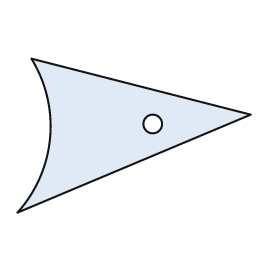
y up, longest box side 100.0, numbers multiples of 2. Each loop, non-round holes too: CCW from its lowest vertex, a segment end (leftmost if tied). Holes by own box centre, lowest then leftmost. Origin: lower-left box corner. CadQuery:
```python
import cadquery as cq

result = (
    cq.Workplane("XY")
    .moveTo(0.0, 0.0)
    .lineTo(100.0, 42.0)
    .lineTo(6.0, 66.0)
    .threePointArc((14.0, 32.0), (0.0, 0.0))
    .close()
    .moveTo(58.0, 38.0)
    .circle(4.0)
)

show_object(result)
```